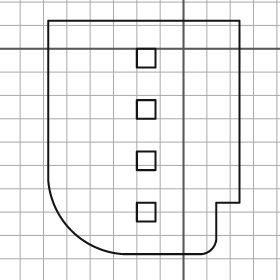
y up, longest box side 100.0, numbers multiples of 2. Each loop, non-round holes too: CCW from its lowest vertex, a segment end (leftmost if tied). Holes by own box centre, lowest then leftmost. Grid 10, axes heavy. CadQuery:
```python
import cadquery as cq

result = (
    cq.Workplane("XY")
    .moveTo(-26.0, -88.0)
    .lineTo(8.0, -88.0)
    .threePointArc((12.0, -86.0), (14.0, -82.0))
    .lineTo(14.0, -66.0)
    .lineTo(24.0, -66.0)
    .lineTo(24.0, 12.0)
    .lineTo(-58.0, 12.0)
    .lineTo(-58.0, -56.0)
    .threePointArc((-48.0, -78.0), (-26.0, -88.0))
    .close()
    .moveTo(-20.0, -74.0)
    .lineTo(-12.0, -74.0)
    .lineTo(-12.0, -66.0)
    .lineTo(-20.0, -66.0)
    .close()
    .moveTo(-20.0, -52.0)
    .lineTo(-12.0, -52.0)
    .lineTo(-12.0, -44.0)
    .lineTo(-20.0, -44.0)
    .close()
    .moveTo(-20.0, -30.0)
    .lineTo(-12.0, -30.0)
    .lineTo(-12.0, -22.0)
    .lineTo(-20.0, -22.0)
    .close()
    .moveTo(-20.0, -8.0)
    .lineTo(-12.0, -8.0)
    .lineTo(-12.0, 0.0)
    .lineTo(-20.0, 0.0)
    .close()
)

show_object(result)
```